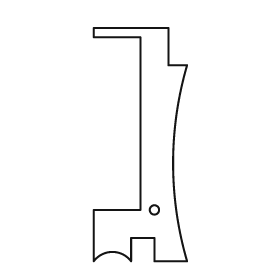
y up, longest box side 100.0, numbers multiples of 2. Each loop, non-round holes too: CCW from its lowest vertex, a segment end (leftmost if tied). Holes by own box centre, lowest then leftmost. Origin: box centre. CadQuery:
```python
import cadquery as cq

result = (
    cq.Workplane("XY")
    .moveTo(-20.0, -50.0)
    .threePointArc((-12.0, -46.0), (-4.0, -50.0))
    .lineTo(-4.0, -40.0)
    .lineTo(6.0, -40.0)
    .lineTo(6.0, -50.0)
    .lineTo(20.0, -50.0)
    .threePointArc((14.0, -8.0), (20.0, 34.0))
    .lineTo(12.0, 34.0)
    .lineTo(12.0, 50.0)
    .lineTo(-20.0, 50.0)
    .lineTo(-20.0, 46.0)
    .lineTo(0.0, 46.0)
    .lineTo(0.0, -28.0)
    .lineTo(-20.0, -28.0)
    .close()
    .moveTo(6.0, -28.0)
    .circle(2.0)
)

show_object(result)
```